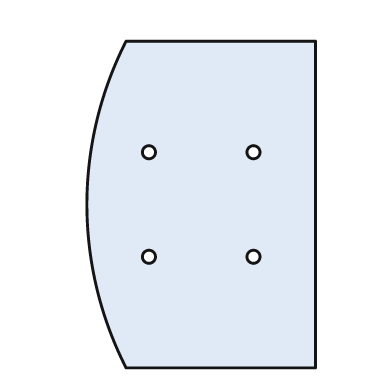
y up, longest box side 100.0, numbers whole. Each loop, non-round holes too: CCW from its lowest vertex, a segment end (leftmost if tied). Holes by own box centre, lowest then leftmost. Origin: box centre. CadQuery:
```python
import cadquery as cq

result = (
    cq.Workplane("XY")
    .moveTo(-23.0, -50.0)
    .lineTo(35.0, -50.0)
    .lineTo(35.0, 50.0)
    .lineTo(-23.0, 50.0)
    .threePointArc((-35.0, 0.0), (-23.0, -50.0))
    .close()
    .moveTo(-16.0, -16.0)
    .circle(2.0)
    .moveTo(16.0, -16.0)
    .circle(2.0)
    .moveTo(-16.0, 16.0)
    .circle(2.0)
    .moveTo(16.0, 16.0)
    .circle(2.0)
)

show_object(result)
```